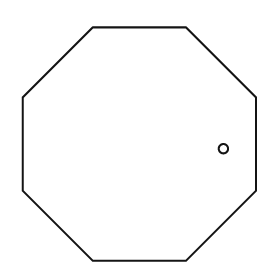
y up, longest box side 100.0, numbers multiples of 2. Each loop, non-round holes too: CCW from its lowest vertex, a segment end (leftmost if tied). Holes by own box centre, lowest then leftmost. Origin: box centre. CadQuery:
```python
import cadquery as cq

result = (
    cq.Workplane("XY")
    .moveTo(-20.0, -50.0)
    .lineTo(20.0, -50.0)
    .lineTo(50.0, -20.0)
    .lineTo(50.0, 20.0)
    .lineTo(20.0, 50.0)
    .lineTo(-20.0, 50.0)
    .lineTo(-50.0, 20.0)
    .lineTo(-50.0, -20.0)
    .close()
    .moveTo(36.0, -2.0)
    .circle(2.0)
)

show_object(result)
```